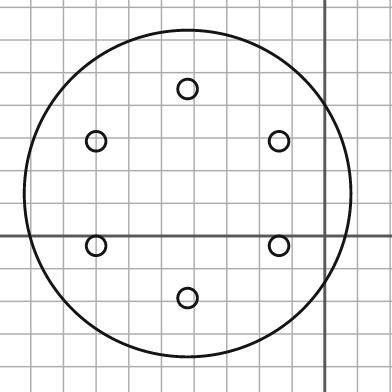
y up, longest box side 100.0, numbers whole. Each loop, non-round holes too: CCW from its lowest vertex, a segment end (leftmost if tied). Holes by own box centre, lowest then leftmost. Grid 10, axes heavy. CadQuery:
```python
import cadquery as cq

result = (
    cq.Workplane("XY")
    .moveTo(-42.0, 13.0)
    .circle(50.0)
    .moveTo(-42.0, -19.0)
    .circle(3.0)
    .moveTo(-70.0, -3.0)
    .circle(3.0)
    .moveTo(-14.0, -3.0)
    .circle(3.0)
    .moveTo(-70.0, 29.0)
    .circle(3.0)
    .moveTo(-14.0, 29.0)
    .circle(3.0)
    .moveTo(-42.0, 45.0)
    .circle(3.0)
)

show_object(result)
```